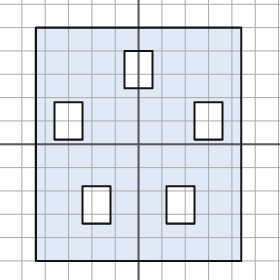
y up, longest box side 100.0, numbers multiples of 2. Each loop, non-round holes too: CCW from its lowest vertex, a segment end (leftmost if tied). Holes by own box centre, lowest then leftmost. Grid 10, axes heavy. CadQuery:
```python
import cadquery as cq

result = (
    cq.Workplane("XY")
    .moveTo(-44.0, -50.0)
    .lineTo(44.0, -50.0)
    .lineTo(44.0, 50.0)
    .lineTo(-44.0, 50.0)
    .close()
    .moveTo(-24.0, -34.0)
    .lineTo(-12.0, -34.0)
    .lineTo(-12.0, -18.0)
    .lineTo(-24.0, -18.0)
    .close()
    .moveTo(12.0, -34.0)
    .lineTo(24.0, -34.0)
    .lineTo(24.0, -18.0)
    .lineTo(12.0, -18.0)
    .close()
    .moveTo(-36.0, 2.0)
    .lineTo(-24.0, 2.0)
    .lineTo(-24.0, 18.0)
    .lineTo(-36.0, 18.0)
    .close()
    .moveTo(24.0, 2.0)
    .lineTo(36.0, 2.0)
    .lineTo(36.0, 18.0)
    .lineTo(24.0, 18.0)
    .close()
    .moveTo(-6.0, 24.0)
    .lineTo(6.0, 24.0)
    .lineTo(6.0, 40.0)
    .lineTo(-6.0, 40.0)
    .close()
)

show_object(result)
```